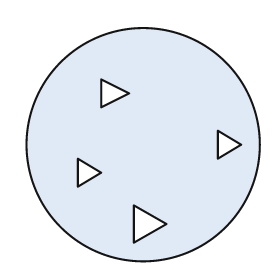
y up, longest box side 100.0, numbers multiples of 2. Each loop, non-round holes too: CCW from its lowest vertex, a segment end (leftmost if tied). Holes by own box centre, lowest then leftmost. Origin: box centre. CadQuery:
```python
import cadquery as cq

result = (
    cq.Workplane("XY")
    .moveTo(0.0, 0.0)
    .circle(50.0)
    .moveTo(-4.0, -42.0)
    .lineTo(10.0, -34.0)
    .lineTo(-4.0, -26.0)
    .close()
    .moveTo(-28.0, -18.0)
    .lineTo(-18.0, -12.0)
    .lineTo(-28.0, -6.0)
    .close()
    .moveTo(32.0, -6.0)
    .lineTo(42.0, 0.0)
    .lineTo(32.0, 6.0)
    .close()
    .moveTo(-18.0, 16.0)
    .lineTo(-6.0, 22.0)
    .lineTo(-18.0, 28.0)
    .close()
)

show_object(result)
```